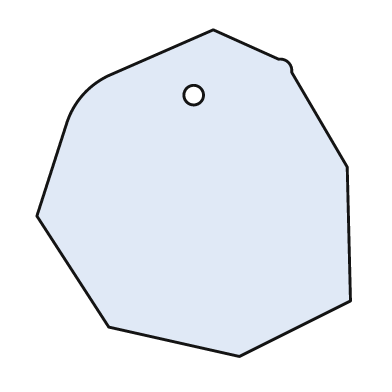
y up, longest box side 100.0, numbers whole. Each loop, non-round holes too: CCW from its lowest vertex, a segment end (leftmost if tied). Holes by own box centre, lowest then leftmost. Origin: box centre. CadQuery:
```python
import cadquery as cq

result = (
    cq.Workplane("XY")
    .moveTo(14.0, -50.0)
    .lineTo(48.0, -33.0)
    .lineTo(47.0, 8.0)
    .lineTo(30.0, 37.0)
    .threePointArc((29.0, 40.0), (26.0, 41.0))
    .lineTo(6.0, 50.0)
    .lineTo(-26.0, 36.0)
    .threePointArc((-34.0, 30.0), (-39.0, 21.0))
    .lineTo(-48.0, -7.0)
    .lineTo(-26.0, -41.0)
    .close()
    .moveTo(0.0, 30.0)
    .circle(3.0)
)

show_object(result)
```